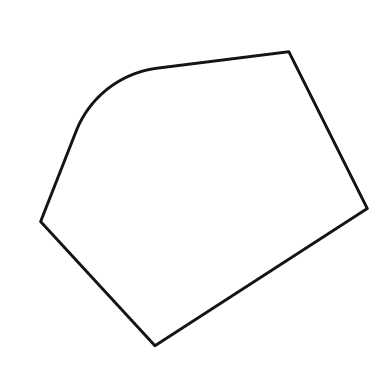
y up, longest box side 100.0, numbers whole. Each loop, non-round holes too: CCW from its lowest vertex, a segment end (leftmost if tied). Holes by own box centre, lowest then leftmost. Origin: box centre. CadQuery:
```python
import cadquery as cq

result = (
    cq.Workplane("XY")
    .moveTo(-15.0, -45.0)
    .lineTo(50.0, -3.0)
    .lineTo(26.0, 45.0)
    .lineTo(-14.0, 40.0)
    .threePointArc((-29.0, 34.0), (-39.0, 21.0))
    .lineTo(-50.0, -7.0)
    .close()
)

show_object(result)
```